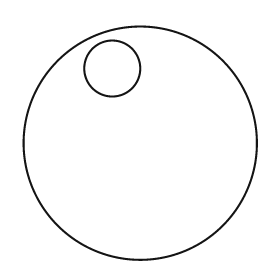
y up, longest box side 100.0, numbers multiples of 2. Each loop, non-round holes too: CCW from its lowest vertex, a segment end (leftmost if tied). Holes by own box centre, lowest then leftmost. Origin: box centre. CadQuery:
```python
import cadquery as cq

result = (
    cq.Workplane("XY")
    .moveTo(0.0, 0.0)
    .circle(50.0)
    .moveTo(-12.0, 32.0)
    .circle(12.0)
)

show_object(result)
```